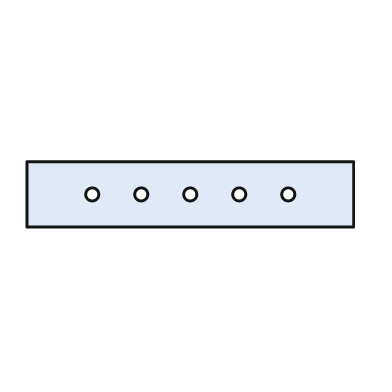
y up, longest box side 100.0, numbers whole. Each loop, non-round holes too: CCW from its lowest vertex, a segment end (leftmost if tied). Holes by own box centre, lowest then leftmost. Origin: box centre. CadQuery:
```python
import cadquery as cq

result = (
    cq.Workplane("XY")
    .moveTo(-50.0, -10.0)
    .lineTo(50.0, -10.0)
    .lineTo(50.0, 10.0)
    .lineTo(-50.0, 10.0)
    .close()
    .moveTo(-30.0, 0.0)
    .circle(2.0)
    .moveTo(-15.0, 0.0)
    .circle(2.0)
    .moveTo(0.0, 0.0)
    .circle(2.0)
    .moveTo(15.0, 0.0)
    .circle(2.0)
    .moveTo(30.0, 0.0)
    .circle(2.0)
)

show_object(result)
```